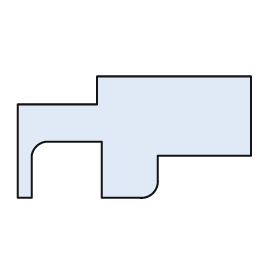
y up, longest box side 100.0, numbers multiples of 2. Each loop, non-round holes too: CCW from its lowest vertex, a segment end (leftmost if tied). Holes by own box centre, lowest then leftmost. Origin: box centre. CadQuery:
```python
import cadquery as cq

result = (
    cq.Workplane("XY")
    .moveTo(-50.0, -26.0)
    .lineTo(-44.0, -26.0)
    .lineTo(-44.0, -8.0)
    .threePointArc((-42.0, -4.0), (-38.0, -2.0))
    .lineTo(-14.0, -2.0)
    .lineTo(-14.0, -26.0)
    .lineTo(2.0, -26.0)
    .threePointArc((8.0, -24.0), (10.0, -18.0))
    .lineTo(10.0, -8.0)
    .lineTo(50.0, -8.0)
    .lineTo(50.0, 26.0)
    .lineTo(-16.0, 26.0)
    .lineTo(-16.0, 14.0)
    .lineTo(-50.0, 14.0)
    .close()
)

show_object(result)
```